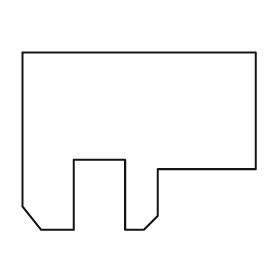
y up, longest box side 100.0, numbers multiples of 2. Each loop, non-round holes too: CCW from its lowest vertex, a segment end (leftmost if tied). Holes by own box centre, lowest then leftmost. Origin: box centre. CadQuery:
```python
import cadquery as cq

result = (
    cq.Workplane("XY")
    .moveTo(-42.0, -38.0)
    .lineTo(-28.0, -38.0)
    .lineTo(-28.0, -8.0)
    .lineTo(-6.0, -8.0)
    .lineTo(-6.0, -38.0)
    .lineTo(2.0, -38.0)
    .lineTo(8.0, -32.0)
    .lineTo(8.0, -12.0)
    .lineTo(50.0, -12.0)
    .lineTo(50.0, 38.0)
    .lineTo(-50.0, 38.0)
    .lineTo(-50.0, -28.0)
    .close()
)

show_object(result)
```